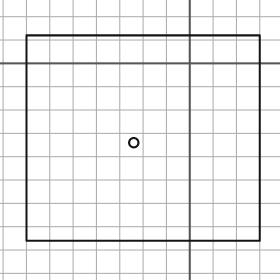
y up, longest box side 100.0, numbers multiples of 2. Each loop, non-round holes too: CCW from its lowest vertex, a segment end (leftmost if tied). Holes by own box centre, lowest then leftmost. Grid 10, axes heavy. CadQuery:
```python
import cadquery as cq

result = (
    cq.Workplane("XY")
    .moveTo(-70.0, -76.0)
    .lineTo(30.0, -76.0)
    .lineTo(30.0, 12.0)
    .lineTo(-70.0, 12.0)
    .close()
    .moveTo(-24.0, -34.0)
    .circle(2.0)
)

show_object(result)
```